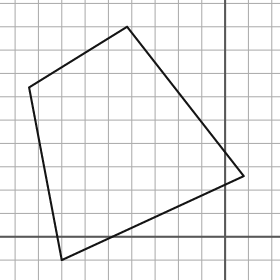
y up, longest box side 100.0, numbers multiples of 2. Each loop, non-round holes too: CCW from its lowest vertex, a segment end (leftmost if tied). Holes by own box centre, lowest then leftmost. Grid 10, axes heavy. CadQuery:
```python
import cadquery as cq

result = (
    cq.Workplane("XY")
    .moveTo(-70.0, -10.0)
    .lineTo(8.0, 26.0)
    .lineTo(-42.0, 90.0)
    .lineTo(-84.0, 64.0)
    .close()
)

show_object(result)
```